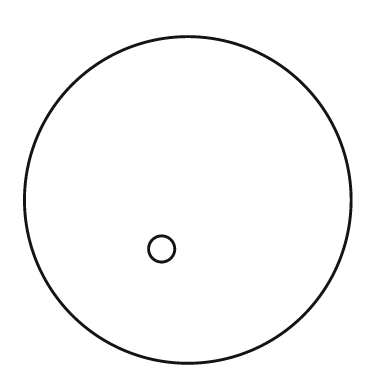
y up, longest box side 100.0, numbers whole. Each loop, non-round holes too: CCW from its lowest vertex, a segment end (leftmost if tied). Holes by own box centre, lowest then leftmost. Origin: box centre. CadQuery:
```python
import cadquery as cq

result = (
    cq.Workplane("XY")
    .moveTo(0.0, 0.0)
    .circle(50.0)
    .moveTo(-8.0, -15.0)
    .circle(4.0)
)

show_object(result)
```